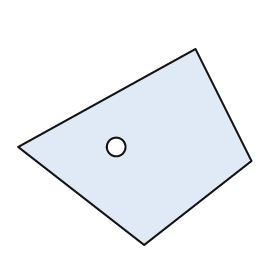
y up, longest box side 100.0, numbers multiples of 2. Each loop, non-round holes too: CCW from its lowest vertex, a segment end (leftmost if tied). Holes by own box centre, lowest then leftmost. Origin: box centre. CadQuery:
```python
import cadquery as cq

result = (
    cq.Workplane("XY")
    .moveTo(4.0, -42.0)
    .lineTo(50.0, -6.0)
    .lineTo(26.0, 42.0)
    .lineTo(-50.0, 0.0)
    .close()
    .moveTo(-8.0, 0.0)
    .circle(4.0)
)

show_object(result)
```